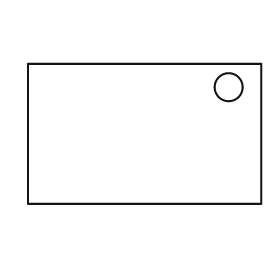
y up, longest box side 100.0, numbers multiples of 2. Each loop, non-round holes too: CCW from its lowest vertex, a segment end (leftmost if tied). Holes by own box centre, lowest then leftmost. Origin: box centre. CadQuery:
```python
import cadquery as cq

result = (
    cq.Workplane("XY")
    .moveTo(-50.0, -30.0)
    .lineTo(50.0, -30.0)
    .lineTo(50.0, 30.0)
    .lineTo(-50.0, 30.0)
    .close()
    .moveTo(36.0, 20.0)
    .circle(6.0)
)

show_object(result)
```